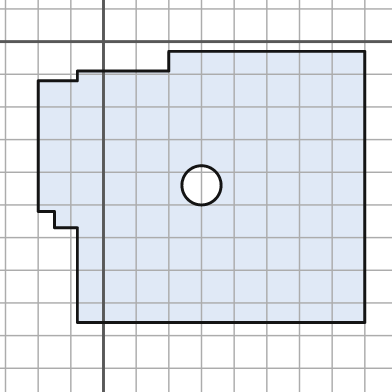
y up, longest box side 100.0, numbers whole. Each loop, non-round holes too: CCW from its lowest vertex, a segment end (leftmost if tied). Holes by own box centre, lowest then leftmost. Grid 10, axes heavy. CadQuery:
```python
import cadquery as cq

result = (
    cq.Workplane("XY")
    .moveTo(-8.0, -86.0)
    .lineTo(80.0, -86.0)
    .lineTo(80.0, -3.0)
    .lineTo(20.0, -3.0)
    .lineTo(20.0, -9.0)
    .lineTo(-8.0, -9.0)
    .lineTo(-8.0, -12.0)
    .lineTo(-20.0, -12.0)
    .lineTo(-20.0, -52.0)
    .lineTo(-15.0, -52.0)
    .lineTo(-15.0, -57.0)
    .lineTo(-8.0, -57.0)
    .close()
    .moveTo(30.0, -44.0)
    .circle(6.0)
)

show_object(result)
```